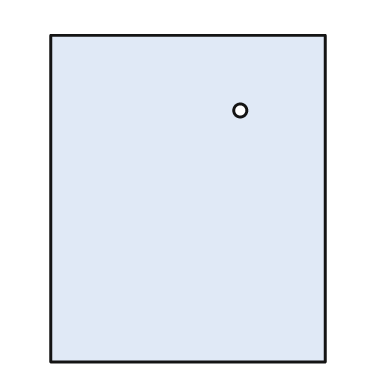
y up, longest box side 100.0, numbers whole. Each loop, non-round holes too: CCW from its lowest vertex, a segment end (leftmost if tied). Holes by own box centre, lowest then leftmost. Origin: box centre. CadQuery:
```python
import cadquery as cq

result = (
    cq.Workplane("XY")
    .moveTo(-42.0, -50.0)
    .lineTo(42.0, -50.0)
    .lineTo(42.0, 50.0)
    .lineTo(-42.0, 50.0)
    .close()
    .moveTo(16.0, 27.0)
    .circle(2.0)
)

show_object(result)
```